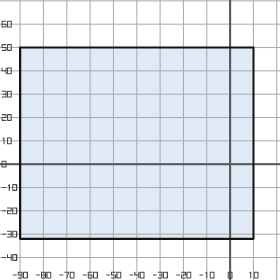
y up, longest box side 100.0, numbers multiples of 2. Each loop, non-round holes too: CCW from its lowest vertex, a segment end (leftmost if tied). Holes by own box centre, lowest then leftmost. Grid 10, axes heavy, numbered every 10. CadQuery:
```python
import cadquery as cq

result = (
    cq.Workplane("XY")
    .moveTo(-90.0, -32.0)
    .lineTo(10.0, -32.0)
    .lineTo(10.0, 50.0)
    .lineTo(-90.0, 50.0)
    .close()
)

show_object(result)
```